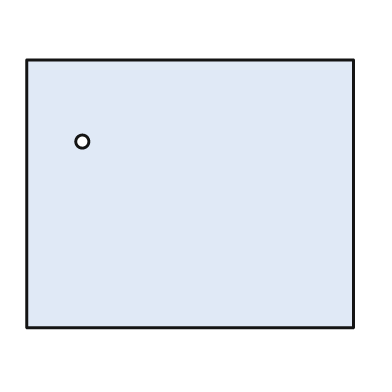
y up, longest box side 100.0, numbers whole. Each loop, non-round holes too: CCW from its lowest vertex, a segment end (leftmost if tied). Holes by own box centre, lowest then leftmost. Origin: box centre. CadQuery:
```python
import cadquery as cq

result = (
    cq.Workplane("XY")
    .moveTo(-50.0, -41.0)
    .lineTo(50.0, -41.0)
    .lineTo(50.0, 41.0)
    .lineTo(-50.0, 41.0)
    .close()
    .moveTo(-33.0, 16.0)
    .circle(2.0)
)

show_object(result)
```